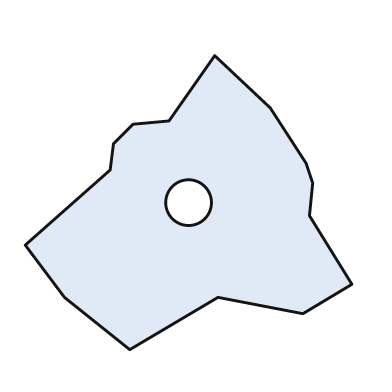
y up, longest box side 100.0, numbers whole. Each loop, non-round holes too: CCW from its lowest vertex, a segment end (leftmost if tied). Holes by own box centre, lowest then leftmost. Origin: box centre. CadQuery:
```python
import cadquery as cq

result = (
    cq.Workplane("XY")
    .moveTo(-18.0, -45.0)
    .lineTo(9.0, -29.0)
    .lineTo(35.0, -34.0)
    .lineTo(50.0, -25.0)
    .lineTo(37.0, -4.0)
    .lineTo(38.0, 6.0)
    .lineTo(36.0, 12.0)
    .lineTo(25.0, 29.0)
    .lineTo(8.0, 45.0)
    .lineTo(-6.0, 25.0)
    .lineTo(-17.0, 24.0)
    .lineTo(-23.0, 18.0)
    .lineTo(-24.0, 10.0)
    .lineTo(-50.0, -13.0)
    .lineTo(-38.0, -29.0)
    .close()
    .moveTo(0.0, 0.0)
    .circle(7.0)
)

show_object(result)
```